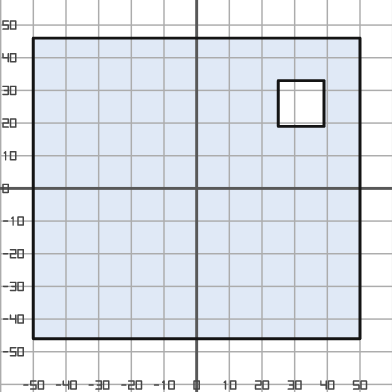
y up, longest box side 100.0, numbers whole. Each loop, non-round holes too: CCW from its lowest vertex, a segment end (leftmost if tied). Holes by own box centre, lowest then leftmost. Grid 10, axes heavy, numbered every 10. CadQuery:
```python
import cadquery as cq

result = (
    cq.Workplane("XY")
    .moveTo(-50.0, -46.0)
    .lineTo(50.0, -46.0)
    .lineTo(50.0, 46.0)
    .lineTo(-50.0, 46.0)
    .close()
    .moveTo(25.0, 19.0)
    .lineTo(39.0, 19.0)
    .lineTo(39.0, 33.0)
    .lineTo(25.0, 33.0)
    .close()
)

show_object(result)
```